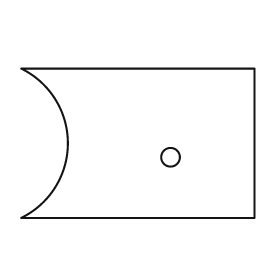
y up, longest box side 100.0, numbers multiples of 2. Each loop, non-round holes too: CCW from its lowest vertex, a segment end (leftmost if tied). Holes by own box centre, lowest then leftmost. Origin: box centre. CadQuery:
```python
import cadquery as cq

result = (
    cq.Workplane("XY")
    .moveTo(-50.0, -32.0)
    .lineTo(50.0, -32.0)
    .lineTo(50.0, 32.0)
    .lineTo(-50.0, 32.0)
    .threePointArc((-30.0, 0.0), (-50.0, -32.0))
    .close()
    .moveTo(14.0, -6.0)
    .circle(4.0)
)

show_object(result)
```